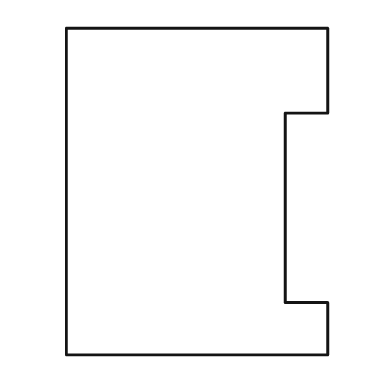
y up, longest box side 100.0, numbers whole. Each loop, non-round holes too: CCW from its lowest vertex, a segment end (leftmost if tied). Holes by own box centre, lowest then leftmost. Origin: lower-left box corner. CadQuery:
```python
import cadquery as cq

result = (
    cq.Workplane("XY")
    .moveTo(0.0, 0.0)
    .lineTo(80.0, 0.0)
    .lineTo(80.0, 16.0)
    .lineTo(67.0, 16.0)
    .lineTo(67.0, 74.0)
    .lineTo(80.0, 74.0)
    .lineTo(80.0, 100.0)
    .lineTo(0.0, 100.0)
    .close()
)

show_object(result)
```